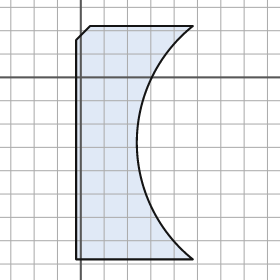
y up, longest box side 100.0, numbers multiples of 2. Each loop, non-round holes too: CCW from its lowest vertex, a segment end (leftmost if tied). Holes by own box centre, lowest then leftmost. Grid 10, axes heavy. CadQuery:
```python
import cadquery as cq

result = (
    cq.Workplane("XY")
    .moveTo(-2.0, -78.0)
    .lineTo(48.0, -78.0)
    .threePointArc((24.0, -28.0), (48.0, 22.0))
    .lineTo(4.0, 22.0)
    .lineTo(-2.0, 16.0)
    .close()
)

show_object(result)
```